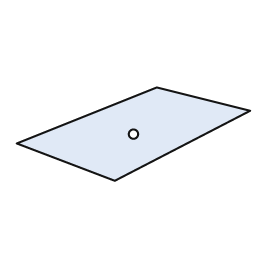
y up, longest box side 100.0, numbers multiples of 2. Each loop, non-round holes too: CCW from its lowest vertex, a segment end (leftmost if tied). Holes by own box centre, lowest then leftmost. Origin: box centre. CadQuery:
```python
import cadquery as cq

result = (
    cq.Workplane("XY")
    .moveTo(-8.0, -20.0)
    .lineTo(50.0, 10.0)
    .lineTo(10.0, 20.0)
    .lineTo(-50.0, -4.0)
    .close()
    .moveTo(0.0, 0.0)
    .circle(2.0)
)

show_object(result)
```